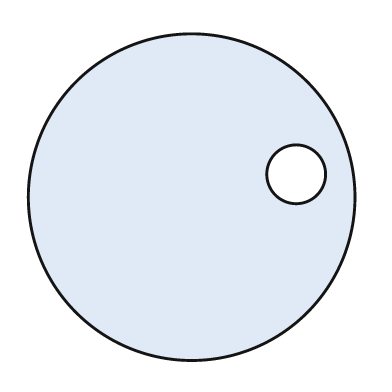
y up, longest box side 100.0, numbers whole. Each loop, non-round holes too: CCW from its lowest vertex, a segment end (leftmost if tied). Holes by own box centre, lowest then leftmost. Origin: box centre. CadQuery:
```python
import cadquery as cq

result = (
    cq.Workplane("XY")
    .moveTo(0.0, 0.0)
    .circle(50.0)
    .moveTo(32.0, 7.0)
    .circle(9.0)
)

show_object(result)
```